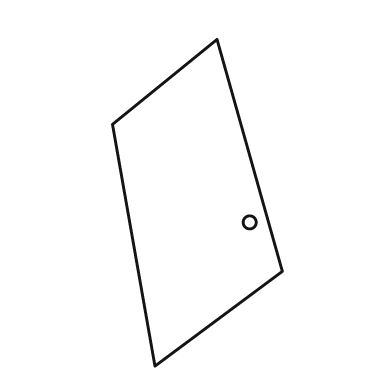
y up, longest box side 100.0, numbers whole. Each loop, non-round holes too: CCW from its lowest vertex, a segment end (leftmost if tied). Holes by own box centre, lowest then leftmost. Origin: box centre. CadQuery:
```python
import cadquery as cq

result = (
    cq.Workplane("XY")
    .moveTo(-13.0, -50.0)
    .lineTo(26.0, -21.0)
    .lineTo(6.0, 50.0)
    .lineTo(-26.0, 24.0)
    .close()
    .moveTo(16.0, -6.0)
    .circle(2.0)
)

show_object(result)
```